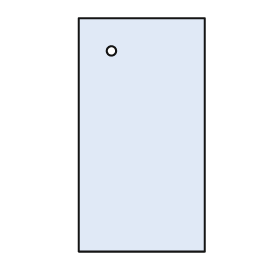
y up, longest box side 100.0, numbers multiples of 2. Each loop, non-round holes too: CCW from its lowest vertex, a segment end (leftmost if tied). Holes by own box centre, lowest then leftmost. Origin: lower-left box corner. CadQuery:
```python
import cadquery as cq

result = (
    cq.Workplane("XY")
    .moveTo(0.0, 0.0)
    .lineTo(54.0, 0.0)
    .lineTo(54.0, 100.0)
    .lineTo(0.0, 100.0)
    .close()
    .moveTo(14.0, 86.0)
    .circle(2.0)
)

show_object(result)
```